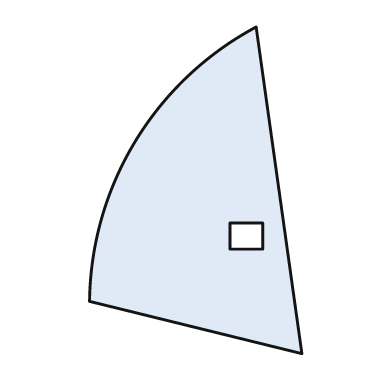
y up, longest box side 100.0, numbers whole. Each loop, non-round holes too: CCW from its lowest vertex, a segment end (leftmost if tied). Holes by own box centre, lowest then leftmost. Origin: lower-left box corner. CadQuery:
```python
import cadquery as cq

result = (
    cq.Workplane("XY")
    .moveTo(65.0, 0.0)
    .lineTo(51.0, 100.0)
    .threePointArc((14.0, 65.0), (0.0, 16.0))
    .close()
    .moveTo(43.0, 32.0)
    .lineTo(53.0, 32.0)
    .lineTo(53.0, 40.0)
    .lineTo(43.0, 40.0)
    .close()
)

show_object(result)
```